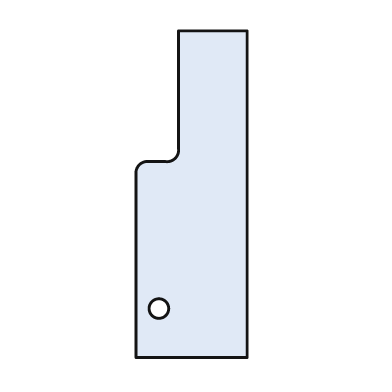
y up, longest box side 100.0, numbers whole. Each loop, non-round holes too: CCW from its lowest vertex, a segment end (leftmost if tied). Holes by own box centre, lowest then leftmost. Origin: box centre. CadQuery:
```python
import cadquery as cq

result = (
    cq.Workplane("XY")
    .moveTo(-17.0, -50.0)
    .lineTo(17.0, -50.0)
    .lineTo(17.0, 50.0)
    .lineTo(-4.0, 50.0)
    .lineTo(-4.0, 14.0)
    .threePointArc((-5.0, 11.0), (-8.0, 10.0))
    .lineTo(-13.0, 10.0)
    .threePointArc((-16.0, 9.0), (-17.0, 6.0))
    .close()
    .moveTo(-10.0, -35.0)
    .circle(3.0)
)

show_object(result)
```